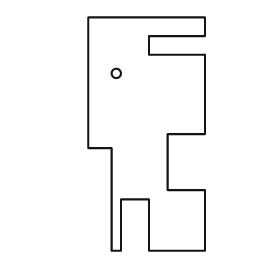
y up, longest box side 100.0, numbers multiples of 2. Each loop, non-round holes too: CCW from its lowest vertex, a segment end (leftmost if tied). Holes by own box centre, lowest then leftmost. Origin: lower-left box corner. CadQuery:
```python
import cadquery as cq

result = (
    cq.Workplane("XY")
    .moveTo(10.0, 0.0)
    .lineTo(14.0, 0.0)
    .lineTo(14.0, 22.0)
    .lineTo(26.0, 22.0)
    .lineTo(26.0, 0.0)
    .lineTo(50.0, 0.0)
    .lineTo(50.0, 26.0)
    .lineTo(34.0, 26.0)
    .lineTo(34.0, 50.0)
    .lineTo(50.0, 50.0)
    .lineTo(50.0, 84.0)
    .lineTo(26.0, 84.0)
    .lineTo(26.0, 92.0)
    .lineTo(50.0, 92.0)
    .lineTo(50.0, 100.0)
    .lineTo(0.0, 100.0)
    .lineTo(0.0, 44.0)
    .lineTo(10.0, 44.0)
    .close()
    .moveTo(12.0, 76.0)
    .circle(2.0)
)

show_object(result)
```